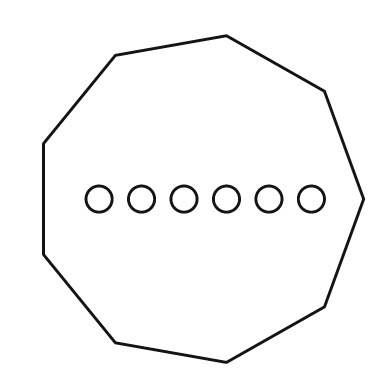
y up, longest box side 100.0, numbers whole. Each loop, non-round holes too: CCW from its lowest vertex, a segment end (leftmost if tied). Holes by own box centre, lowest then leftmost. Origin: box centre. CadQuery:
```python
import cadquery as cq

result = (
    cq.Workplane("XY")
    .moveTo(7.0, -50.0)
    .lineTo(37.0, -33.0)
    .lineTo(49.0, 0.0)
    .lineTo(37.0, 33.0)
    .lineTo(7.0, 50.0)
    .lineTo(-27.0, 44.0)
    .lineTo(-49.0, 17.0)
    .lineTo(-49.0, -17.0)
    .lineTo(-27.0, -44.0)
    .close()
    .moveTo(-32.0, 0.0)
    .circle(4.0)
    .moveTo(-19.0, 0.0)
    .circle(4.0)
    .moveTo(-6.0, 0.0)
    .circle(4.0)
    .moveTo(7.0, 0.0)
    .circle(4.0)
    .moveTo(20.0, 0.0)
    .circle(4.0)
    .moveTo(33.0, 0.0)
    .circle(4.0)
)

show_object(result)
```